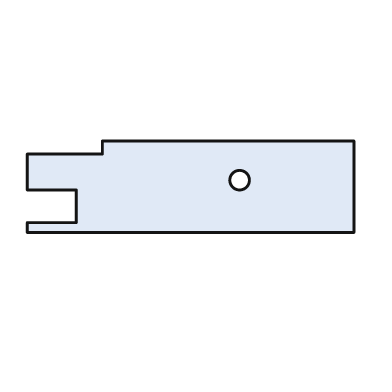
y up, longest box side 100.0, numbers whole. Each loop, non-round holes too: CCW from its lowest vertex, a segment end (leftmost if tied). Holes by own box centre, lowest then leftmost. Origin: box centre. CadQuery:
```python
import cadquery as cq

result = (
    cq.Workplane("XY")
    .moveTo(-50.0, -14.0)
    .lineTo(50.0, -14.0)
    .lineTo(50.0, 14.0)
    .lineTo(-27.0, 14.0)
    .lineTo(-27.0, 10.0)
    .lineTo(-50.0, 10.0)
    .lineTo(-50.0, -1.0)
    .lineTo(-35.0, -1.0)
    .lineTo(-35.0, -11.0)
    .lineTo(-50.0, -11.0)
    .close()
    .moveTo(15.0, 2.0)
    .circle(3.0)
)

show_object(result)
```